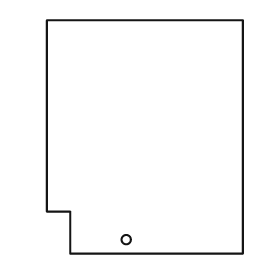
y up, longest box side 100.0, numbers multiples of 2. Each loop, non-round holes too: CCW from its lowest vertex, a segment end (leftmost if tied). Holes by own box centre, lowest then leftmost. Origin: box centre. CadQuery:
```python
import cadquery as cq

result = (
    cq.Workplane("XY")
    .moveTo(-32.0, -50.0)
    .lineTo(42.0, -50.0)
    .lineTo(42.0, 50.0)
    .lineTo(-42.0, 50.0)
    .lineTo(-42.0, -32.0)
    .lineTo(-32.0, -32.0)
    .close()
    .moveTo(-8.0, -44.0)
    .circle(2.0)
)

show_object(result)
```